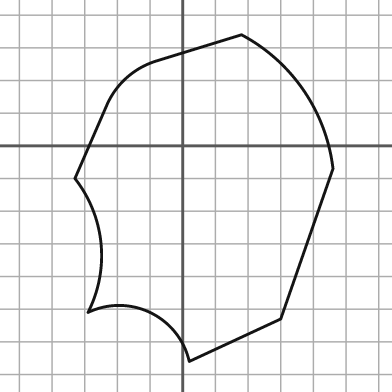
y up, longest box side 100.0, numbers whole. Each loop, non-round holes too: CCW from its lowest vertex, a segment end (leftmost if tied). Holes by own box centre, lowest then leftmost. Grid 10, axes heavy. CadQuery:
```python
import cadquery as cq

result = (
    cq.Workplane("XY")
    .moveTo(2.0, -66.0)
    .lineTo(30.0, -53.0)
    .lineTo(46.0, -7.0)
    .threePointArc((37.0, 17.0), (18.0, 34.0))
    .lineTo(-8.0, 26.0)
    .threePointArc((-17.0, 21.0), (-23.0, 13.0))
    .lineTo(-33.0, -10.0)
    .threePointArc((-25.0, -30.0), (-29.0, -51.0))
    .threePointArc((-10.0, -51.0), (2.0, -66.0))
    .close()
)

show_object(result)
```